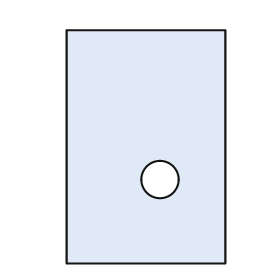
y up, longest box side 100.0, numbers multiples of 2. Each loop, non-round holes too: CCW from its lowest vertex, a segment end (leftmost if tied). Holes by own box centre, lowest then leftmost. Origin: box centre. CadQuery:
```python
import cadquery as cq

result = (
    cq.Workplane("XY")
    .moveTo(-34.0, -50.0)
    .lineTo(34.0, -50.0)
    .lineTo(34.0, 50.0)
    .lineTo(-34.0, 50.0)
    .close()
    .moveTo(6.0, -14.0)
    .circle(8.0)
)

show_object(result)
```